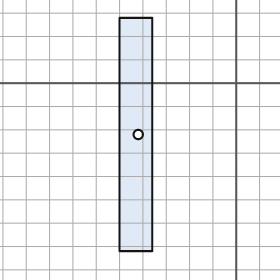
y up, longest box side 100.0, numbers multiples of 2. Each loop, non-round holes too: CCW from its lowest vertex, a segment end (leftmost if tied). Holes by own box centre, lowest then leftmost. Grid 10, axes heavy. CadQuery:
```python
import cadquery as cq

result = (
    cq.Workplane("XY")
    .moveTo(-50.0, -72.0)
    .lineTo(-36.0, -72.0)
    .lineTo(-36.0, 28.0)
    .lineTo(-50.0, 28.0)
    .close()
    .moveTo(-42.0, -22.0)
    .circle(2.0)
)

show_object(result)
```